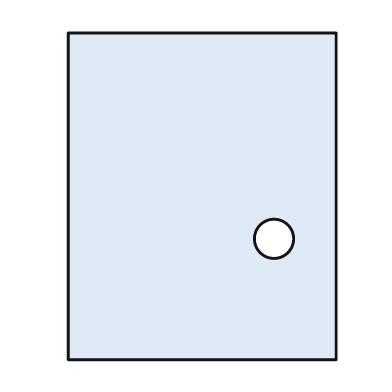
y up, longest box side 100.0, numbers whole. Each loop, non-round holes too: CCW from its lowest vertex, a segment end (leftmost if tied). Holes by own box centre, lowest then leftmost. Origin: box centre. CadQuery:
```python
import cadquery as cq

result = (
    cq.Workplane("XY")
    .moveTo(-41.0, -50.0)
    .lineTo(41.0, -50.0)
    .lineTo(41.0, 50.0)
    .lineTo(-41.0, 50.0)
    .close()
    .moveTo(22.0, -13.0)
    .circle(6.0)
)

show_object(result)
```